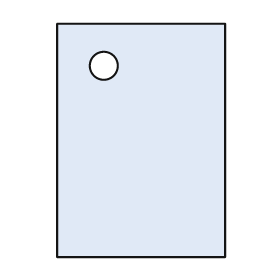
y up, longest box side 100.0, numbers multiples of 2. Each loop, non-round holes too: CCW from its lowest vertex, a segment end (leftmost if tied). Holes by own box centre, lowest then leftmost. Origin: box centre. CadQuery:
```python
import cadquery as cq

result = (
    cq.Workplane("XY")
    .moveTo(-36.0, -50.0)
    .lineTo(36.0, -50.0)
    .lineTo(36.0, 50.0)
    .lineTo(-36.0, 50.0)
    .close()
    .moveTo(-16.0, 32.0)
    .circle(6.0)
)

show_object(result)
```